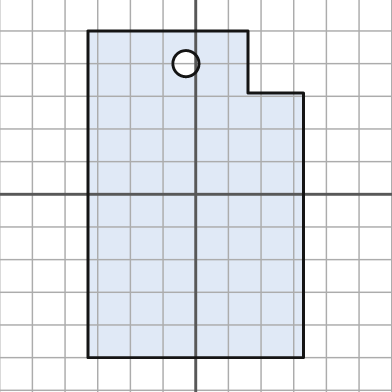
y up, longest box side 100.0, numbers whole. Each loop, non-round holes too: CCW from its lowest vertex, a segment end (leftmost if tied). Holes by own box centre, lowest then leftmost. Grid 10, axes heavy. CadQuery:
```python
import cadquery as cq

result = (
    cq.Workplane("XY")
    .moveTo(-33.0, -50.0)
    .lineTo(33.0, -50.0)
    .lineTo(33.0, 31.0)
    .lineTo(16.0, 31.0)
    .lineTo(16.0, 50.0)
    .lineTo(-33.0, 50.0)
    .close()
    .moveTo(-3.0, 40.0)
    .circle(4.0)
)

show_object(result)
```